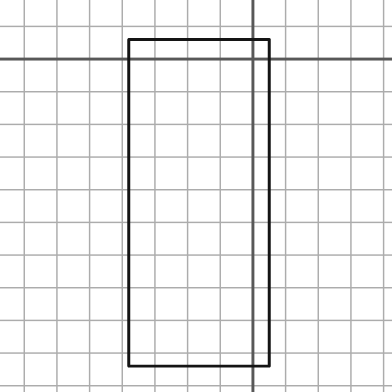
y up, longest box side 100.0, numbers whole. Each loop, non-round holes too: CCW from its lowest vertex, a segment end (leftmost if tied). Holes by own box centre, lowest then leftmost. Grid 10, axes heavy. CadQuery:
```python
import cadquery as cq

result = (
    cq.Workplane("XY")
    .moveTo(-38.0, -94.0)
    .lineTo(5.0, -94.0)
    .lineTo(5.0, 6.0)
    .lineTo(-38.0, 6.0)
    .close()
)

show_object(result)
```